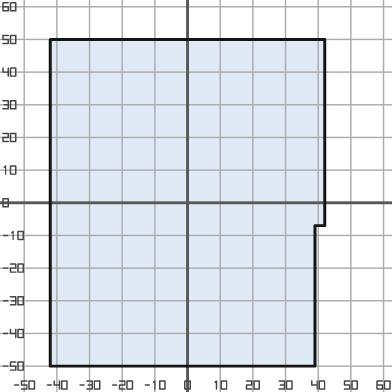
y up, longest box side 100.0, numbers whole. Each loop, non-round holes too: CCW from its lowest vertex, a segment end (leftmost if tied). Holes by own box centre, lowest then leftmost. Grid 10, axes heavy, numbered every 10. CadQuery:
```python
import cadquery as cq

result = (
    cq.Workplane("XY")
    .moveTo(-42.0, -50.0)
    .lineTo(39.0, -50.0)
    .lineTo(39.0, -7.0)
    .lineTo(42.0, -7.0)
    .lineTo(42.0, 50.0)
    .lineTo(-42.0, 50.0)
    .close()
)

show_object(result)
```